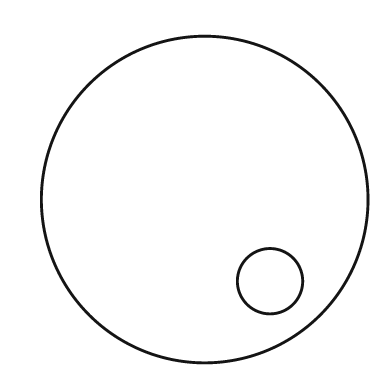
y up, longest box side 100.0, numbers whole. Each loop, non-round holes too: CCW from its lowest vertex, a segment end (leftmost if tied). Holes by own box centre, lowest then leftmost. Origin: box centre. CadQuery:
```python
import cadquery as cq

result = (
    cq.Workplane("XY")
    .moveTo(0.0, 0.0)
    .circle(50.0)
    .moveTo(20.0, -25.0)
    .circle(10.0)
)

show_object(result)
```